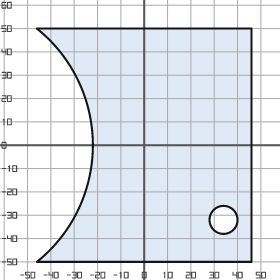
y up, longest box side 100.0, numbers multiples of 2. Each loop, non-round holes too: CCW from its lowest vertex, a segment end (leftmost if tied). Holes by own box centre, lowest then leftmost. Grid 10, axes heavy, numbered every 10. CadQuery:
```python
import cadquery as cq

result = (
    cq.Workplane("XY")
    .moveTo(-46.0, -50.0)
    .lineTo(46.0, -50.0)
    .lineTo(46.0, 50.0)
    .lineTo(-46.0, 50.0)
    .threePointArc((-22.0, 0.0), (-46.0, -50.0))
    .close()
    .moveTo(34.0, -32.0)
    .circle(6.0)
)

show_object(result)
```